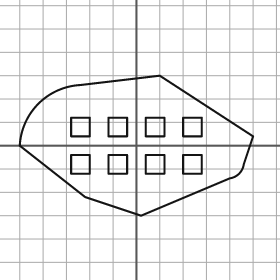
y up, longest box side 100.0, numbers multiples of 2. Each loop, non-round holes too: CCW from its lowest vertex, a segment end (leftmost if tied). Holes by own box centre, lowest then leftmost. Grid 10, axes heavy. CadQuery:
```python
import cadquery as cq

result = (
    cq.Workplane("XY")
    .moveTo(2.0, -30.0)
    .lineTo(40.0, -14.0)
    .threePointArc((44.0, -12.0), (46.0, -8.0))
    .lineTo(50.0, 4.0)
    .lineTo(10.0, 30.0)
    .lineTo(-24.0, 26.0)
    .threePointArc((-42.0, 18.0), (-50.0, 0.0))
    .lineTo(-22.0, -22.0)
    .close()
    .moveTo(-28.0, -12.0)
    .lineTo(-20.0, -12.0)
    .lineTo(-20.0, -4.0)
    .lineTo(-28.0, -4.0)
    .close()
    .moveTo(-12.0, -12.0)
    .lineTo(-4.0, -12.0)
    .lineTo(-4.0, -4.0)
    .lineTo(-12.0, -4.0)
    .close()
    .moveTo(4.0, -12.0)
    .lineTo(12.0, -12.0)
    .lineTo(12.0, -4.0)
    .lineTo(4.0, -4.0)
    .close()
    .moveTo(20.0, -12.0)
    .lineTo(28.0, -12.0)
    .lineTo(28.0, -4.0)
    .lineTo(20.0, -4.0)
    .close()
    .moveTo(-28.0, 4.0)
    .lineTo(-20.0, 4.0)
    .lineTo(-20.0, 12.0)
    .lineTo(-28.0, 12.0)
    .close()
    .moveTo(-12.0, 4.0)
    .lineTo(-4.0, 4.0)
    .lineTo(-4.0, 12.0)
    .lineTo(-12.0, 12.0)
    .close()
    .moveTo(4.0, 4.0)
    .lineTo(12.0, 4.0)
    .lineTo(12.0, 12.0)
    .lineTo(4.0, 12.0)
    .close()
    .moveTo(20.0, 4.0)
    .lineTo(28.0, 4.0)
    .lineTo(28.0, 12.0)
    .lineTo(20.0, 12.0)
    .close()
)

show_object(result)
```